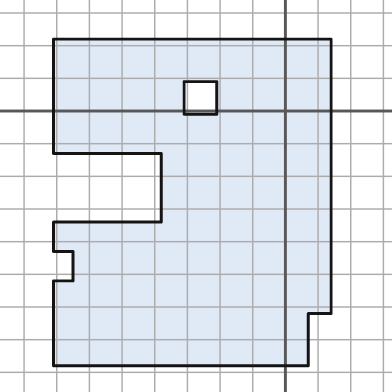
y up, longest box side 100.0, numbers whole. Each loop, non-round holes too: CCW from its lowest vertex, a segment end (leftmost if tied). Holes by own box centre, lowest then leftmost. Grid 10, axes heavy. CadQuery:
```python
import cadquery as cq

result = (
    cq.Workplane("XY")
    .moveTo(-71.0, -78.0)
    .lineTo(7.0, -78.0)
    .lineTo(7.0, -62.0)
    .lineTo(14.0, -62.0)
    .lineTo(14.0, 22.0)
    .lineTo(-71.0, 22.0)
    .lineTo(-71.0, -13.0)
    .lineTo(-38.0, -13.0)
    .lineTo(-38.0, -34.0)
    .lineTo(-71.0, -34.0)
    .lineTo(-71.0, -43.0)
    .lineTo(-65.0, -43.0)
    .lineTo(-65.0, -52.0)
    .lineTo(-71.0, -52.0)
    .close()
    .moveTo(-31.0, -1.0)
    .lineTo(-21.0, -1.0)
    .lineTo(-21.0, 9.0)
    .lineTo(-31.0, 9.0)
    .close()
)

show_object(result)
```